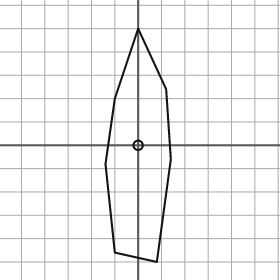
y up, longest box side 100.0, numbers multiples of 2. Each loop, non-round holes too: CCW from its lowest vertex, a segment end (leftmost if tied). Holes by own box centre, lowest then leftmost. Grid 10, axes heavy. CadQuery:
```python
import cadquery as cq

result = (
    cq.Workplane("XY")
    .moveTo(8.0, -50.0)
    .lineTo(14.0, -6.0)
    .lineTo(12.0, 24.0)
    .lineTo(0.0, 50.0)
    .lineTo(-10.0, 20.0)
    .lineTo(-14.0, -8.0)
    .lineTo(-10.0, -46.0)
    .close()
    .moveTo(0.0, 0.0)
    .circle(2.0)
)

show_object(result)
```